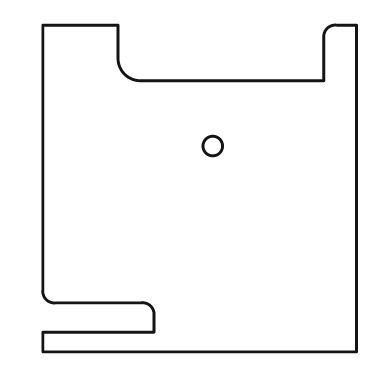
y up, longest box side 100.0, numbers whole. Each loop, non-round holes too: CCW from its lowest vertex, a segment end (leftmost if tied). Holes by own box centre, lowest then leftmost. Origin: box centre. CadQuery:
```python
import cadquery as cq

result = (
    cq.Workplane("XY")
    .moveTo(-48.0, -50.0)
    .lineTo(48.0, -50.0)
    .lineTo(48.0, 50.0)
    .lineTo(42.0, 50.0)
    .threePointArc((39.0, 49.0), (38.0, 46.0))
    .lineTo(38.0, 33.0)
    .lineTo(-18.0, 33.0)
    .threePointArc((-23.0, 35.0), (-25.0, 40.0))
    .lineTo(-25.0, 50.0)
    .lineTo(-48.0, 50.0)
    .lineTo(-48.0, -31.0)
    .threePointArc((-47.0, -34.0), (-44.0, -35.0))
    .lineTo(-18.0, -35.0)
    .threePointArc((-15.0, -36.0), (-14.0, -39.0))
    .lineTo(-14.0, -44.0)
    .lineTo(-48.0, -44.0)
    .close()
    .moveTo(4.0, 13.0)
    .circle(3.0)
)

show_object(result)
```